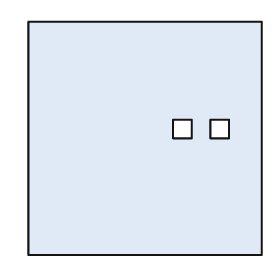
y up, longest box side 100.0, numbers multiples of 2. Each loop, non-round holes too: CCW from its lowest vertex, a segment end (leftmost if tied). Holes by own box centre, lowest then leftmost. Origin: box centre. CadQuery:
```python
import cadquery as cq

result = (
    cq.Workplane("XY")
    .moveTo(-50.0, -50.0)
    .lineTo(50.0, -50.0)
    .lineTo(50.0, 50.0)
    .lineTo(-50.0, 50.0)
    .close()
    .moveTo(12.0, 0.0)
    .lineTo(20.0, 0.0)
    .lineTo(20.0, 8.0)
    .lineTo(12.0, 8.0)
    .close()
    .moveTo(28.0, 0.0)
    .lineTo(36.0, 0.0)
    .lineTo(36.0, 8.0)
    .lineTo(28.0, 8.0)
    .close()
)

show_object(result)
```